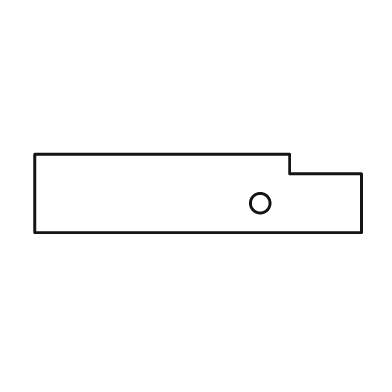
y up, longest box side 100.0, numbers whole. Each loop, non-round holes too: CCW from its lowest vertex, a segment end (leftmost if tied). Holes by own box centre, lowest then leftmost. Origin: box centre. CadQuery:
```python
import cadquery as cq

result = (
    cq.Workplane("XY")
    .moveTo(-50.0, -12.0)
    .lineTo(50.0, -12.0)
    .lineTo(50.0, 6.0)
    .lineTo(28.0, 6.0)
    .lineTo(28.0, 12.0)
    .lineTo(-50.0, 12.0)
    .close()
    .moveTo(19.0, -3.0)
    .circle(3.0)
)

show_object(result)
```